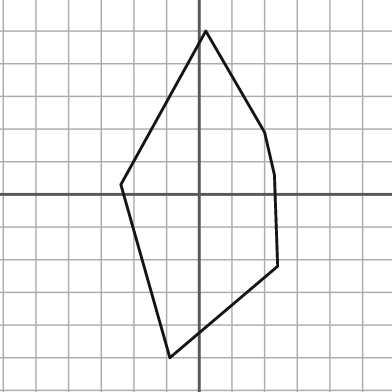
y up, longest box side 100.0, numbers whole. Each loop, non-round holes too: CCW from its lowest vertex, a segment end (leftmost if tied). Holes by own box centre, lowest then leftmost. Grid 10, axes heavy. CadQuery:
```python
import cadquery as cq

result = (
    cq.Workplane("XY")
    .moveTo(-9.0, -50.0)
    .lineTo(24.0, -22.0)
    .lineTo(23.0, 6.0)
    .lineTo(20.0, 19.0)
    .lineTo(2.0, 50.0)
    .lineTo(-24.0, 3.0)
    .close()
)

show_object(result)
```